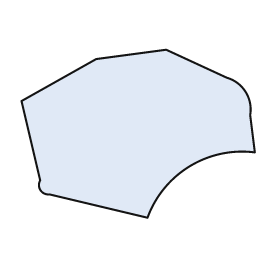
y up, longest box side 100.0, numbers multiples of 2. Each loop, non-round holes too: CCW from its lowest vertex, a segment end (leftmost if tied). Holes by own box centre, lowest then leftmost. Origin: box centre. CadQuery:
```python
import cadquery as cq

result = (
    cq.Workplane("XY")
    .moveTo(4.0, -36.0)
    .threePointArc((22.0, -14.0), (50.0, -8.0))
    .lineTo(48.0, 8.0)
    .threePointArc((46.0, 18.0), (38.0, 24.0))
    .lineTo(12.0, 36.0)
    .lineTo(-18.0, 32.0)
    .lineTo(-50.0, 14.0)
    .lineTo(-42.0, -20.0)
    .threePointArc((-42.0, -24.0), (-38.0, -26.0))
    .close()
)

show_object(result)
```